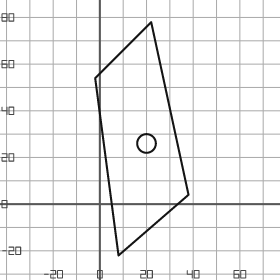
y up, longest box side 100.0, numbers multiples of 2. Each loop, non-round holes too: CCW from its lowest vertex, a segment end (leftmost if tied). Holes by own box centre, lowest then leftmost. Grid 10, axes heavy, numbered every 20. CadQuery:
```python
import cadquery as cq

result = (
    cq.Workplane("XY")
    .moveTo(8.0, -22.0)
    .lineTo(38.0, 4.0)
    .lineTo(22.0, 78.0)
    .lineTo(-2.0, 54.0)
    .close()
    .moveTo(20.0, 26.0)
    .circle(4.0)
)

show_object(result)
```